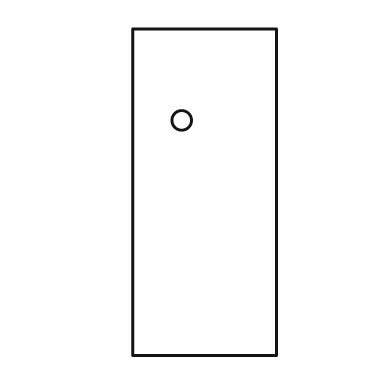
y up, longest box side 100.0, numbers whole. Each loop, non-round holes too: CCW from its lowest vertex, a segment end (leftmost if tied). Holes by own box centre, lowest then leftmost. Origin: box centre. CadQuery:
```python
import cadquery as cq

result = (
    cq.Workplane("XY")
    .moveTo(-22.0, -50.0)
    .lineTo(22.0, -50.0)
    .lineTo(22.0, 50.0)
    .lineTo(-22.0, 50.0)
    .close()
    .moveTo(-7.0, 22.0)
    .circle(3.0)
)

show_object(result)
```